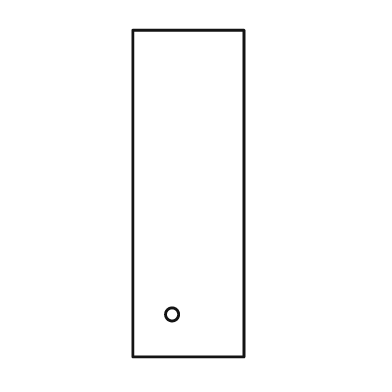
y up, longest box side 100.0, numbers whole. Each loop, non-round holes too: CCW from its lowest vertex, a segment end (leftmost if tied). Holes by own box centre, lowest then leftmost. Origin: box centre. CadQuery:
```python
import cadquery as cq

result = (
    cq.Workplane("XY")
    .moveTo(-17.0, -50.0)
    .lineTo(17.0, -50.0)
    .lineTo(17.0, 50.0)
    .lineTo(-17.0, 50.0)
    .close()
    .moveTo(-5.0, -37.0)
    .circle(2.0)
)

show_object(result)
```